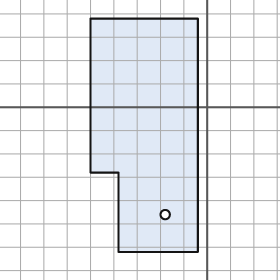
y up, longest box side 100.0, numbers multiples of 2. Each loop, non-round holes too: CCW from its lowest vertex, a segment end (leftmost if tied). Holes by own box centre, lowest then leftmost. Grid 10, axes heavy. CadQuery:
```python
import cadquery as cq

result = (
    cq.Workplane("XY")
    .moveTo(-38.0, -62.0)
    .lineTo(-4.0, -62.0)
    .lineTo(-4.0, 38.0)
    .lineTo(-50.0, 38.0)
    .lineTo(-50.0, -28.0)
    .lineTo(-38.0, -28.0)
    .close()
    .moveTo(-18.0, -46.0)
    .circle(2.0)
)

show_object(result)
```